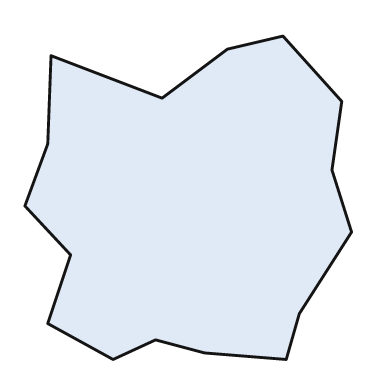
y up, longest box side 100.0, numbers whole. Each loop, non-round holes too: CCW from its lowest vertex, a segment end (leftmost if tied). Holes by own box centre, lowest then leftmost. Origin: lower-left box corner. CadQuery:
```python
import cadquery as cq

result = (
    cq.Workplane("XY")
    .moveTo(27.0, 0.0)
    .lineTo(40.0, 6.0)
    .lineTo(55.0, 2.0)
    .lineTo(80.0, 0.0)
    .lineTo(84.0, 14.0)
    .lineTo(100.0, 39.0)
    .lineTo(94.0, 58.0)
    .lineTo(97.0, 79.0)
    .lineTo(79.0, 99.0)
    .lineTo(62.0, 95.0)
    .lineTo(42.0, 80.0)
    .lineTo(8.0, 93.0)
    .lineTo(7.0, 66.0)
    .lineTo(0.0, 47.0)
    .lineTo(14.0, 32.0)
    .lineTo(7.0, 11.0)
    .close()
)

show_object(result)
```